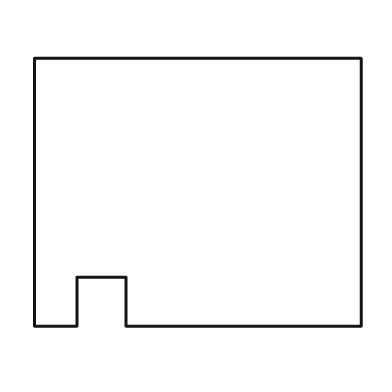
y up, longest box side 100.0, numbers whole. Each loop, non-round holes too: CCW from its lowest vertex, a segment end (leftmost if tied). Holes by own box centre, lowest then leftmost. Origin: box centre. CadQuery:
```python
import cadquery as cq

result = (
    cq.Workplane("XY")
    .moveTo(-50.0, -41.0)
    .lineTo(-37.0, -41.0)
    .lineTo(-37.0, -26.0)
    .lineTo(-22.0, -26.0)
    .lineTo(-22.0, -41.0)
    .lineTo(50.0, -41.0)
    .lineTo(50.0, 41.0)
    .lineTo(-50.0, 41.0)
    .close()
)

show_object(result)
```